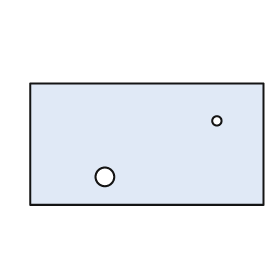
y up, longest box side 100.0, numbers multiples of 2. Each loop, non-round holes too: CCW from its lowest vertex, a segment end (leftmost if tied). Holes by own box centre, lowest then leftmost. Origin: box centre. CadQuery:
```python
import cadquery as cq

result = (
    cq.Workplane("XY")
    .moveTo(-50.0, -26.0)
    .lineTo(50.0, -26.0)
    .lineTo(50.0, 26.0)
    .lineTo(-50.0, 26.0)
    .close()
    .moveTo(-18.0, -14.0)
    .circle(4.0)
    .moveTo(30.0, 10.0)
    .circle(2.0)
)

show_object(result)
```